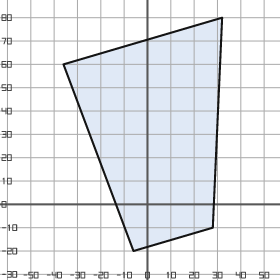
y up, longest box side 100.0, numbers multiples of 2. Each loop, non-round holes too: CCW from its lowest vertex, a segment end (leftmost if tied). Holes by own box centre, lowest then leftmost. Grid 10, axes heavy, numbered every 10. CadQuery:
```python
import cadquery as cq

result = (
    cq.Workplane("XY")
    .moveTo(-6.0, -20.0)
    .lineTo(28.0, -10.0)
    .lineTo(32.0, 80.0)
    .lineTo(-36.0, 60.0)
    .close()
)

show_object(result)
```